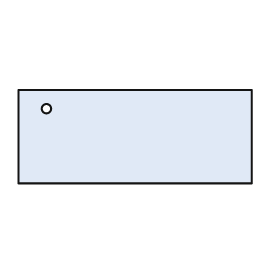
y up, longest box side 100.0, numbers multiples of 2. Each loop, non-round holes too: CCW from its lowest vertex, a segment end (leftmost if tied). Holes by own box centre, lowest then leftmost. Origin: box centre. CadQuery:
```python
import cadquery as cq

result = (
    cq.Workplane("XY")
    .moveTo(-50.0, -20.0)
    .lineTo(50.0, -20.0)
    .lineTo(50.0, 20.0)
    .lineTo(-50.0, 20.0)
    .close()
    .moveTo(-38.0, 12.0)
    .circle(2.0)
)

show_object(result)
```